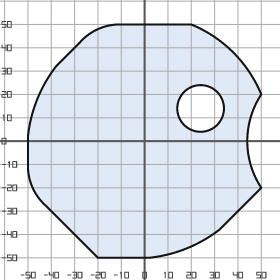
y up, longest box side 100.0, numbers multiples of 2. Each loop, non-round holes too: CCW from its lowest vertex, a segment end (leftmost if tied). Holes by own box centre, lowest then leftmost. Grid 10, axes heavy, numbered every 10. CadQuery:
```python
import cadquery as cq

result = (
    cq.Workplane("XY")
    .moveTo(-20.0, -50.0)
    .lineTo(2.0, -50.0)
    .threePointArc((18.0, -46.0), (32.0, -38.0))
    .lineTo(50.0, -20.0)
    .threePointArc((44.0, 0.0), (50.0, 20.0))
    .threePointArc((38.0, 38.0), (20.0, 50.0))
    .lineTo(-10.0, 50.0)
    .threePointArc((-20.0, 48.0), (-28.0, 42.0))
    .lineTo(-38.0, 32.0)
    .threePointArc((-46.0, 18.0), (-50.0, 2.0))
    .lineTo(-50.0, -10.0)
    .threePointArc((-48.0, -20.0), (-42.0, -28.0))
    .close()
    .moveTo(24.0, 14.0)
    .circle(10.0)
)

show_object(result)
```